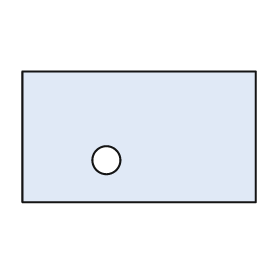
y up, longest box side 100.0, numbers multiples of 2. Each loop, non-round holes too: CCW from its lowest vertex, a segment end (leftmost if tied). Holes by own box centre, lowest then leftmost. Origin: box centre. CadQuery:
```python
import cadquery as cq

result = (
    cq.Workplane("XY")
    .moveTo(-50.0, -28.0)
    .lineTo(50.0, -28.0)
    .lineTo(50.0, 28.0)
    .lineTo(-50.0, 28.0)
    .close()
    .moveTo(-14.0, -10.0)
    .circle(6.0)
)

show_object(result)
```